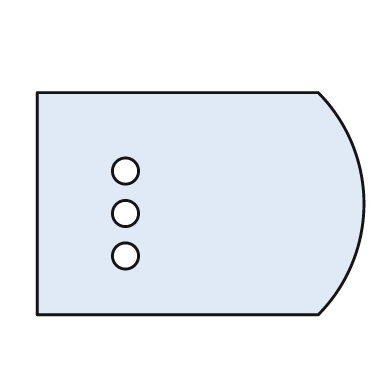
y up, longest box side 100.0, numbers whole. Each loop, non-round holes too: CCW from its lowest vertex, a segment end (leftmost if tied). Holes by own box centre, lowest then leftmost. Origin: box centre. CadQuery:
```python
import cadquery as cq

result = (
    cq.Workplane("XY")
    .moveTo(-50.0, -34.0)
    .lineTo(36.0, -34.0)
    .threePointArc((50.0, 0.0), (36.0, 34.0))
    .lineTo(-50.0, 34.0)
    .close()
    .moveTo(-23.0, -16.0)
    .circle(4.0)
    .moveTo(-23.0, -3.0)
    .circle(4.0)
    .moveTo(-23.0, 10.0)
    .circle(4.0)
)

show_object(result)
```